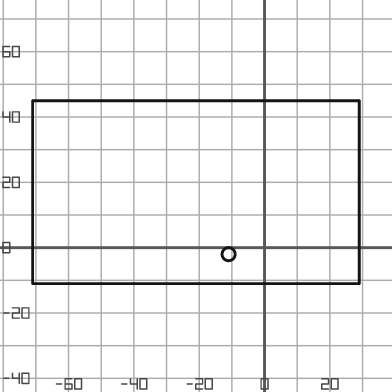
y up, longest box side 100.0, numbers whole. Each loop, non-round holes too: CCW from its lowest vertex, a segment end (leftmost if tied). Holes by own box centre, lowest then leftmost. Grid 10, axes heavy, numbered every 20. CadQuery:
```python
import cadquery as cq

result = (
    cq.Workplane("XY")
    .moveTo(-71.0, -11.0)
    .lineTo(29.0, -11.0)
    .lineTo(29.0, 45.0)
    .lineTo(-71.0, 45.0)
    .close()
    .moveTo(-11.0, -2.0)
    .circle(2.0)
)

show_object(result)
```